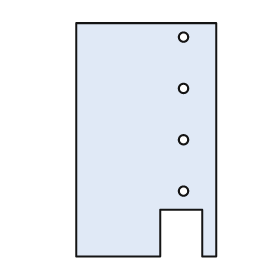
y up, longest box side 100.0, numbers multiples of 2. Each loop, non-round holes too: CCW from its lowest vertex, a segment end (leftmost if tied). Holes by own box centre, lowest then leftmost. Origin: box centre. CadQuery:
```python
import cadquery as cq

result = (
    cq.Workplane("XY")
    .moveTo(-30.0, -50.0)
    .lineTo(6.0, -50.0)
    .lineTo(6.0, -30.0)
    .lineTo(24.0, -30.0)
    .lineTo(24.0, -50.0)
    .lineTo(30.0, -50.0)
    .lineTo(30.0, 50.0)
    .lineTo(-30.0, 50.0)
    .close()
    .moveTo(16.0, -22.0)
    .circle(2.0)
    .moveTo(16.0, 0.0)
    .circle(2.0)
    .moveTo(16.0, 22.0)
    .circle(2.0)
    .moveTo(16.0, 44.0)
    .circle(2.0)
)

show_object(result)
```